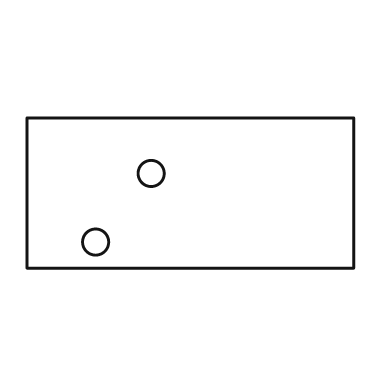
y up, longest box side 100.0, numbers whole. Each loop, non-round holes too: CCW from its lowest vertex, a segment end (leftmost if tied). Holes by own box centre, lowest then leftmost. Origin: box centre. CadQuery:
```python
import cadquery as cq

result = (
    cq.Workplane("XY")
    .moveTo(-50.0, -23.0)
    .lineTo(50.0, -23.0)
    .lineTo(50.0, 23.0)
    .lineTo(-50.0, 23.0)
    .close()
    .moveTo(-29.0, -15.0)
    .circle(4.0)
    .moveTo(-12.0, 6.0)
    .circle(4.0)
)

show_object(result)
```